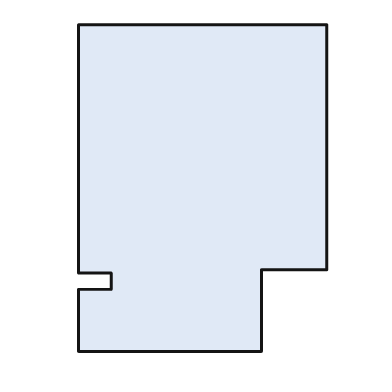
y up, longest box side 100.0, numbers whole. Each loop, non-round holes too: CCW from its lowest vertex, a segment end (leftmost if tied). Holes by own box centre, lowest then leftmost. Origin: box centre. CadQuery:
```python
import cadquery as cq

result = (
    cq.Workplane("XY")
    .moveTo(-38.0, -50.0)
    .lineTo(18.0, -50.0)
    .lineTo(18.0, -25.0)
    .lineTo(38.0, -25.0)
    .lineTo(38.0, 50.0)
    .lineTo(-38.0, 50.0)
    .lineTo(-38.0, -26.0)
    .lineTo(-28.0, -26.0)
    .lineTo(-28.0, -31.0)
    .lineTo(-38.0, -31.0)
    .close()
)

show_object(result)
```